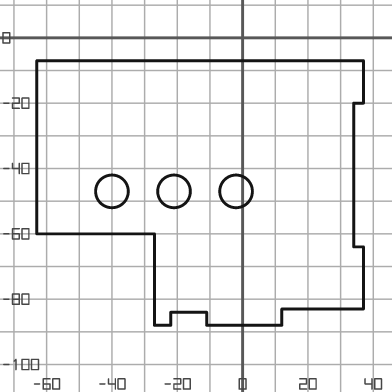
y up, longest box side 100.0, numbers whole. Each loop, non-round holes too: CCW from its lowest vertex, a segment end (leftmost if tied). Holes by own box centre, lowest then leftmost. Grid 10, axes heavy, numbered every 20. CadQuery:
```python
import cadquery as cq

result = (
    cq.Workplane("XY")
    .moveTo(-27.0, -88.0)
    .lineTo(-22.0, -88.0)
    .lineTo(-22.0, -84.0)
    .lineTo(-11.0, -84.0)
    .lineTo(-11.0, -88.0)
    .lineTo(12.0, -88.0)
    .lineTo(12.0, -83.0)
    .lineTo(37.0, -83.0)
    .lineTo(37.0, -64.0)
    .lineTo(34.0, -64.0)
    .lineTo(34.0, -20.0)
    .lineTo(37.0, -20.0)
    .lineTo(37.0, -7.0)
    .lineTo(-63.0, -7.0)
    .lineTo(-63.0, -60.0)
    .lineTo(-27.0, -60.0)
    .close()
    .moveTo(-40.0, -47.0)
    .circle(5.0)
    .moveTo(-21.0, -47.0)
    .circle(5.0)
    .moveTo(-2.0, -47.0)
    .circle(5.0)
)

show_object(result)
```